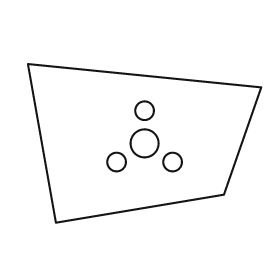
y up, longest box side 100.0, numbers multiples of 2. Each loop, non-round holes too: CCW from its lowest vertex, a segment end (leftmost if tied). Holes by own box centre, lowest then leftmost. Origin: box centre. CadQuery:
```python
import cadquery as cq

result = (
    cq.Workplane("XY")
    .moveTo(-38.0, -34.0)
    .lineTo(34.0, -22.0)
    .lineTo(50.0, 24.0)
    .lineTo(-50.0, 34.0)
    .close()
    .moveTo(-12.0, -8.0)
    .circle(4.0)
    .moveTo(12.0, -8.0)
    .circle(4.0)
    .moveTo(0.0, 0.0)
    .circle(6.0)
    .moveTo(0.0, 14.0)
    .circle(4.0)
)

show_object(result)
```